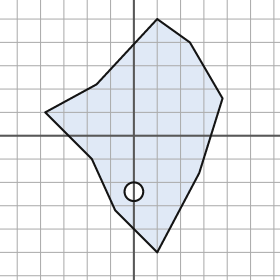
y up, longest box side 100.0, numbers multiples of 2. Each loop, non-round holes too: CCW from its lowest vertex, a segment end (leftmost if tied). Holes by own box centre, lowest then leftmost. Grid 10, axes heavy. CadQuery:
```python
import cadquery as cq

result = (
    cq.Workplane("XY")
    .moveTo(10.0, -50.0)
    .lineTo(28.0, -16.0)
    .lineTo(38.0, 16.0)
    .lineTo(24.0, 40.0)
    .lineTo(10.0, 50.0)
    .lineTo(-16.0, 22.0)
    .lineTo(-38.0, 10.0)
    .lineTo(-18.0, -10.0)
    .lineTo(-8.0, -32.0)
    .close()
    .moveTo(0.0, -24.0)
    .circle(4.0)
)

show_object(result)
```